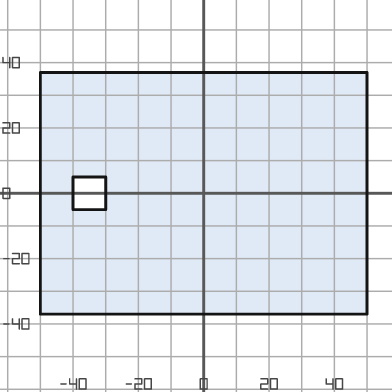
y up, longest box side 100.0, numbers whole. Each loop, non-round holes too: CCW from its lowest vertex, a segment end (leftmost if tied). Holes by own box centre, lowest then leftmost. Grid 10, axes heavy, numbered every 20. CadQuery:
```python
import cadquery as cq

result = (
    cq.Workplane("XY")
    .moveTo(-50.0, -37.0)
    .lineTo(50.0, -37.0)
    .lineTo(50.0, 37.0)
    .lineTo(-50.0, 37.0)
    .close()
    .moveTo(-40.0, -5.0)
    .lineTo(-30.0, -5.0)
    .lineTo(-30.0, 5.0)
    .lineTo(-40.0, 5.0)
    .close()
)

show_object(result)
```